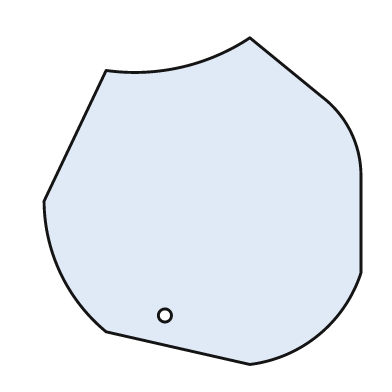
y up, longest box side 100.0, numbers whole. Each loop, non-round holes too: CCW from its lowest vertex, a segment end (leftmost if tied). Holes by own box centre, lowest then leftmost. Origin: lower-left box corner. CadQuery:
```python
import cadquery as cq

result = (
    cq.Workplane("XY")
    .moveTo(63.0, 0.0)
    .threePointArc((84.0, 9.0), (97.0, 28.0))
    .lineTo(97.0, 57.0)
    .threePointArc((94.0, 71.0), (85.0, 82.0))
    .lineTo(63.0, 100.0)
    .threePointArc((42.0, 91.0), (19.0, 90.0))
    .lineTo(0.0, 50.0)
    .threePointArc((5.0, 28.0), (19.0, 10.0))
    .close()
    .moveTo(37.0, 15.0)
    .circle(2.0)
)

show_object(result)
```